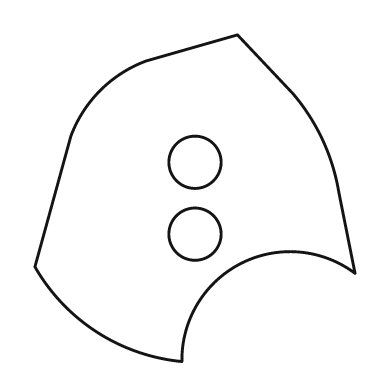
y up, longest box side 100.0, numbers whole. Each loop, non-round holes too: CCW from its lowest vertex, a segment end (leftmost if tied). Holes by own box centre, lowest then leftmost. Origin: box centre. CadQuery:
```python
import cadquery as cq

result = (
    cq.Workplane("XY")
    .moveTo(-4.0, -50.0)
    .threePointArc((14.0, -20.0), (49.0, -23.0))
    .lineTo(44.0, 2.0)
    .threePointArc((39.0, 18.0), (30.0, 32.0))
    .lineTo(13.0, 50.0)
    .lineTo(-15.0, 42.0)
    .threePointArc((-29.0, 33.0), (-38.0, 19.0))
    .lineTo(-49.0, -21.0)
    .threePointArc((-30.0, -41.0), (-4.0, -50.0))
    .close()
    .moveTo(0.0, -11.0)
    .circle(8.0)
    .moveTo(0.0, 11.0)
    .circle(8.0)
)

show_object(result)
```